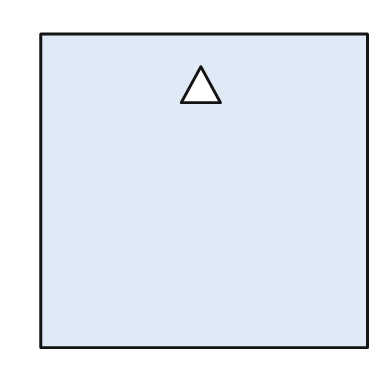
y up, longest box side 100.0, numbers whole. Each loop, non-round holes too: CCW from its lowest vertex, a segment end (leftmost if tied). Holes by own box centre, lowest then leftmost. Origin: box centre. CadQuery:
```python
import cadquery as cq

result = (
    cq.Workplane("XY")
    .moveTo(-50.0, -48.0)
    .lineTo(50.0, -48.0)
    .lineTo(50.0, 48.0)
    .lineTo(-50.0, 48.0)
    .close()
    .moveTo(-7.0, 27.0)
    .lineTo(5.0, 27.0)
    .lineTo(-1.0, 38.0)
    .close()
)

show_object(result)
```